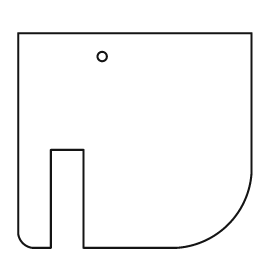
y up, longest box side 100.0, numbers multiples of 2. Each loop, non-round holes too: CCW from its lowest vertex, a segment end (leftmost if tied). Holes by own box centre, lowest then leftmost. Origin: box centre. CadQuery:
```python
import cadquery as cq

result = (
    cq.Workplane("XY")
    .moveTo(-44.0, -46.0)
    .lineTo(-36.0, -46.0)
    .lineTo(-36.0, -4.0)
    .lineTo(-22.0, -4.0)
    .lineTo(-22.0, -46.0)
    .lineTo(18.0, -46.0)
    .threePointArc((40.0, -36.0), (50.0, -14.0))
    .lineTo(50.0, 46.0)
    .lineTo(-50.0, 46.0)
    .lineTo(-50.0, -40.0)
    .threePointArc((-48.0, -44.0), (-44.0, -46.0))
    .close()
    .moveTo(-14.0, 36.0)
    .circle(2.0)
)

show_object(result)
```